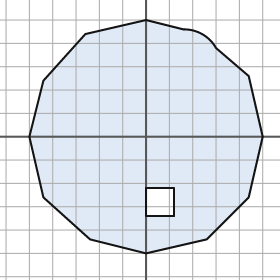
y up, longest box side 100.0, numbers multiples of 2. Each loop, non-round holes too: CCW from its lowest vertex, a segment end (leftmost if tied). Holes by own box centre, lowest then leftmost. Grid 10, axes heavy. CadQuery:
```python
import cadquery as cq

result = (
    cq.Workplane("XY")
    .moveTo(0.0, -50.0)
    .lineTo(26.0, -44.0)
    .lineTo(44.0, -26.0)
    .lineTo(50.0, 0.0)
    .lineTo(44.0, 26.0)
    .lineTo(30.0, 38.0)
    .threePointArc((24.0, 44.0), (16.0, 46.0))
    .lineTo(0.0, 50.0)
    .lineTo(-26.0, 44.0)
    .lineTo(-44.0, 24.0)
    .lineTo(-50.0, 0.0)
    .lineTo(-44.0, -26.0)
    .lineTo(-24.0, -44.0)
    .close()
    .moveTo(0.0, -34.0)
    .lineTo(12.0, -34.0)
    .lineTo(12.0, -22.0)
    .lineTo(0.0, -22.0)
    .close()
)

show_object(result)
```